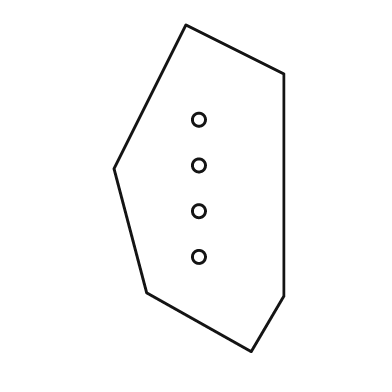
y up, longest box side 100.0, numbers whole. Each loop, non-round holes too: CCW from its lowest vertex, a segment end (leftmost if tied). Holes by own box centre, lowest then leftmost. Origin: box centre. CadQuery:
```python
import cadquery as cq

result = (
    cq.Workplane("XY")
    .moveTo(16.0, -50.0)
    .lineTo(26.0, -33.0)
    .lineTo(26.0, 35.0)
    .lineTo(-4.0, 50.0)
    .lineTo(-26.0, 6.0)
    .lineTo(-16.0, -32.0)
    .close()
    .moveTo(0.0, -21.0)
    .circle(2.0)
    .moveTo(0.0, -7.0)
    .circle(2.0)
    .moveTo(0.0, 7.0)
    .circle(2.0)
    .moveTo(0.0, 21.0)
    .circle(2.0)
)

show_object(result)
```